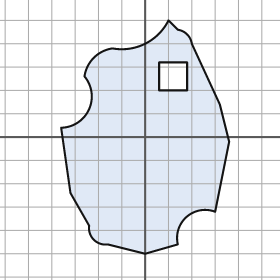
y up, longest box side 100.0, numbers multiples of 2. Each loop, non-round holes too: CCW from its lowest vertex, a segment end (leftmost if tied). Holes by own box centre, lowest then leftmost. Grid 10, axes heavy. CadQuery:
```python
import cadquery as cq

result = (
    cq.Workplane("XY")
    .moveTo(0.0, -50.0)
    .lineTo(14.0, -46.0)
    .threePointArc((18.0, -34.0), (30.0, -32.0))
    .lineTo(36.0, -2.0)
    .lineTo(32.0, 14.0)
    .lineTo(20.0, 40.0)
    .threePointArc((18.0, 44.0), (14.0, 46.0))
    .lineTo(10.0, 50.0)
    .threePointArc((0.0, 40.0), (-14.0, 38.0))
    .threePointArc((-22.0, 34.0), (-26.0, 26.0))
    .threePointArc((-24.0, 12.0), (-36.0, 4.0))
    .lineTo(-32.0, -24.0)
    .lineTo(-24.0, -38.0)
    .threePointArc((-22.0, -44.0), (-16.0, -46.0))
    .close()
    .moveTo(6.0, 20.0)
    .lineTo(18.0, 20.0)
    .lineTo(18.0, 32.0)
    .lineTo(6.0, 32.0)
    .close()
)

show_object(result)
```